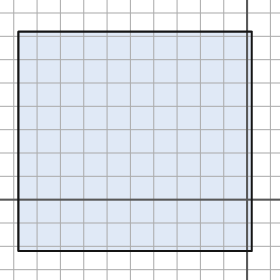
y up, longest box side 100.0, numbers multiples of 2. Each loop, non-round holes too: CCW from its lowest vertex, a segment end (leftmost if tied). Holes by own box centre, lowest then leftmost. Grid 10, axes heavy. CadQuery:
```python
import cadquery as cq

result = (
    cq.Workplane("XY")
    .moveTo(-98.0, -22.0)
    .lineTo(2.0, -22.0)
    .lineTo(2.0, 72.0)
    .lineTo(-98.0, 72.0)
    .close()
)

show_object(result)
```